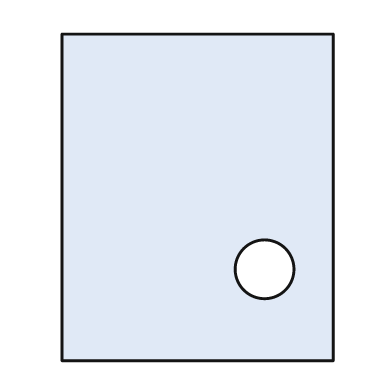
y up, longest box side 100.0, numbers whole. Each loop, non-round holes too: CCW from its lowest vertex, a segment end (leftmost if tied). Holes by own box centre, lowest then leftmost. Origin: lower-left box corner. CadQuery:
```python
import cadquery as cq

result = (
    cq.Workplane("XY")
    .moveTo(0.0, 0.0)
    .lineTo(83.0, 0.0)
    .lineTo(83.0, 100.0)
    .lineTo(0.0, 100.0)
    .close()
    .moveTo(62.0, 28.0)
    .circle(9.0)
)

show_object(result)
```